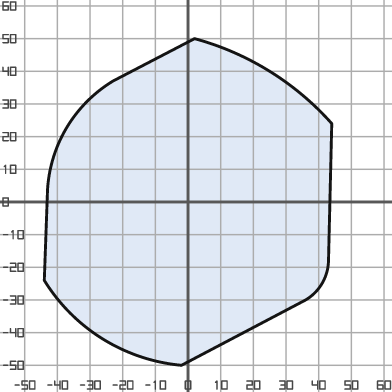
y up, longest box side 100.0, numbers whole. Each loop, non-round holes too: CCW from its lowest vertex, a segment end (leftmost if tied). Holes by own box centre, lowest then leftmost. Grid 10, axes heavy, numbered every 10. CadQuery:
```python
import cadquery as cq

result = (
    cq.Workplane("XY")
    .moveTo(-2.0, -50.0)
    .lineTo(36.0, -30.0)
    .threePointArc((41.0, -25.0), (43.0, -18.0))
    .lineTo(44.0, 24.0)
    .threePointArc((25.0, 40.0), (2.0, 50.0))
    .lineTo(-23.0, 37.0)
    .threePointArc((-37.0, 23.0), (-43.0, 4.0))
    .lineTo(-44.0, -24.0)
    .threePointArc((-26.0, -42.0), (-2.0, -50.0))
    .close()
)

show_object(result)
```